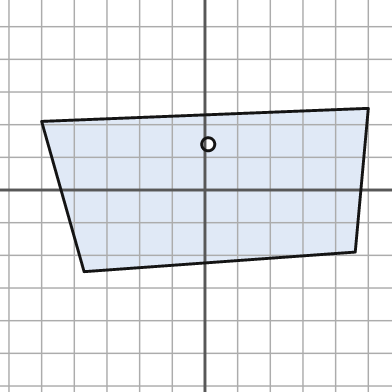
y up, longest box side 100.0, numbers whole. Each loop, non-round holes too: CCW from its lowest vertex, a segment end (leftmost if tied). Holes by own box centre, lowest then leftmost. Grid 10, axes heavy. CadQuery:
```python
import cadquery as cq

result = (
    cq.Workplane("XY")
    .moveTo(-37.0, -25.0)
    .lineTo(46.0, -19.0)
    .lineTo(50.0, 25.0)
    .lineTo(-50.0, 21.0)
    .close()
    .moveTo(1.0, 14.0)
    .circle(2.0)
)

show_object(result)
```